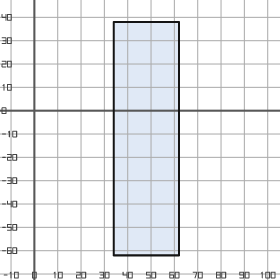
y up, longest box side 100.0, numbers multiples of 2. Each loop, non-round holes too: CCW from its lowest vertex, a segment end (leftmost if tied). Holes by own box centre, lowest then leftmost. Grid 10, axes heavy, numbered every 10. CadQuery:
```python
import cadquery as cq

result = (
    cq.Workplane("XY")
    .moveTo(34.0, -62.0)
    .lineTo(62.0, -62.0)
    .lineTo(62.0, 38.0)
    .lineTo(34.0, 38.0)
    .close()
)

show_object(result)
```